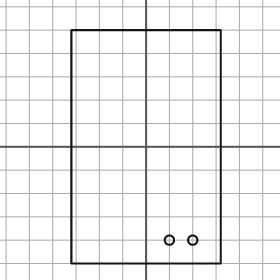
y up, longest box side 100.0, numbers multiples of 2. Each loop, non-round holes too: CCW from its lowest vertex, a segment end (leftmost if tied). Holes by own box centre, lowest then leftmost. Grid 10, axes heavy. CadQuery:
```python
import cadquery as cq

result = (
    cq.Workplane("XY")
    .moveTo(-32.0, -50.0)
    .lineTo(32.0, -50.0)
    .lineTo(32.0, 50.0)
    .lineTo(-32.0, 50.0)
    .close()
    .moveTo(10.0, -40.0)
    .circle(2.0)
    .moveTo(20.0, -40.0)
    .circle(2.0)
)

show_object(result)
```